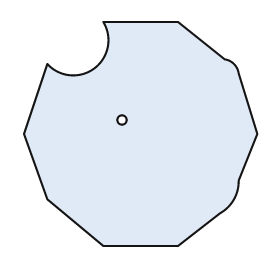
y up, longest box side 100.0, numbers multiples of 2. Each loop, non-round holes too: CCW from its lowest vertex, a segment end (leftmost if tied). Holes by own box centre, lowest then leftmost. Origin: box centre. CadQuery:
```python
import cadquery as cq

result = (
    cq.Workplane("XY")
    .moveTo(-16.0, -48.0)
    .lineTo(16.0, -48.0)
    .lineTo(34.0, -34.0)
    .threePointArc((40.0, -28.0), (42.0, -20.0))
    .lineTo(50.0, 0.0)
    .lineTo(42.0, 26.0)
    .threePointArc((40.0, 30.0), (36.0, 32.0))
    .lineTo(16.0, 48.0)
    .lineTo(-16.0, 48.0)
    .threePointArc((-20.0, 28.0), (-40.0, 30.0))
    .lineTo(-50.0, 0.0)
    .lineTo(-40.0, -28.0)
    .close()
    .moveTo(-8.0, 6.0)
    .circle(2.0)
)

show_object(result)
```